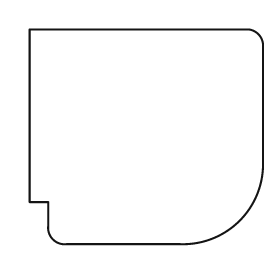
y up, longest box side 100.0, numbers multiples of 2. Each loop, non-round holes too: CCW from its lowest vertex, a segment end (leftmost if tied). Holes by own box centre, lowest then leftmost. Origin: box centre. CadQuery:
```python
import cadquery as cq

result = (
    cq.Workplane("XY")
    .moveTo(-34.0, -46.0)
    .lineTo(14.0, -46.0)
    .threePointArc((40.0, -36.0), (50.0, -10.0))
    .lineTo(50.0, 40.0)
    .threePointArc((48.0, 44.0), (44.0, 46.0))
    .lineTo(-50.0, 46.0)
    .lineTo(-50.0, -28.0)
    .lineTo(-42.0, -28.0)
    .lineTo(-42.0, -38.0)
    .threePointArc((-40.0, -44.0), (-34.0, -46.0))
    .close()
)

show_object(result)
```